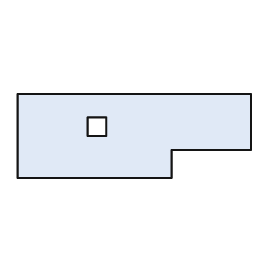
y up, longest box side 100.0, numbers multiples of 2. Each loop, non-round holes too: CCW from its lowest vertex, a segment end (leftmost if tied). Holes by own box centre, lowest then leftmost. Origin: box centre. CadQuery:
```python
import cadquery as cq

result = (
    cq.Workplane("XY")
    .moveTo(-50.0, -18.0)
    .lineTo(16.0, -18.0)
    .lineTo(16.0, -6.0)
    .lineTo(50.0, -6.0)
    .lineTo(50.0, 18.0)
    .lineTo(-50.0, 18.0)
    .close()
    .moveTo(-20.0, 0.0)
    .lineTo(-12.0, 0.0)
    .lineTo(-12.0, 8.0)
    .lineTo(-20.0, 8.0)
    .close()
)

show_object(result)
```